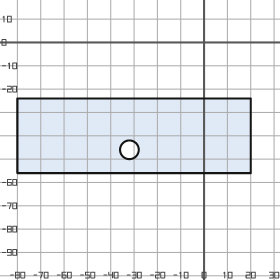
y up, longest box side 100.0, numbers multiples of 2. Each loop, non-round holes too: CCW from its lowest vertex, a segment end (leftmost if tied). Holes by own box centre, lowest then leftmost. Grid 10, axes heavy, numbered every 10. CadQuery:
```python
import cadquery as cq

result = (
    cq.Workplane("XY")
    .moveTo(-80.0, -56.0)
    .lineTo(20.0, -56.0)
    .lineTo(20.0, -24.0)
    .lineTo(-80.0, -24.0)
    .close()
    .moveTo(-32.0, -46.0)
    .circle(4.0)
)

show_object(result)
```